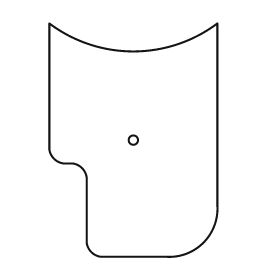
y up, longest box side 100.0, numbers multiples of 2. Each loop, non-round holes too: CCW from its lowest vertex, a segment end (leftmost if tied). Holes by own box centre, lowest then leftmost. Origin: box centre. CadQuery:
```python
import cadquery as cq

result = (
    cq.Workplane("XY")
    .moveTo(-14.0, -50.0)
    .lineTo(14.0, -50.0)
    .threePointArc((30.0, -44.0), (36.0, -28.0))
    .lineTo(36.0, 50.0)
    .threePointArc((0.0, 38.0), (-36.0, 50.0))
    .lineTo(-36.0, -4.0)
    .threePointArc((-34.0, -8.0), (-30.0, -10.0))
    .lineTo(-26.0, -10.0)
    .threePointArc((-22.0, -12.0), (-20.0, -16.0))
    .lineTo(-20.0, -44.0)
    .threePointArc((-18.0, -48.0), (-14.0, -50.0))
    .close()
    .moveTo(0.0, 0.0)
    .circle(2.0)
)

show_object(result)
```